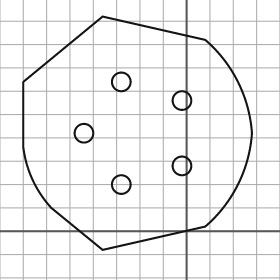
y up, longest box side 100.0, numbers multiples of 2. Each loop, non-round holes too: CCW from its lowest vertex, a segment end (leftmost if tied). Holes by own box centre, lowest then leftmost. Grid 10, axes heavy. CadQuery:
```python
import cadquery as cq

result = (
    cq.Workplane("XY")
    .moveTo(-36.0, -8.0)
    .lineTo(8.0, 2.0)
    .threePointArc((22.0, 20.0), (28.0, 42.0))
    .threePointArc((22.0, 64.0), (8.0, 82.0))
    .lineTo(-36.0, 92.0)
    .lineTo(-70.0, 64.0)
    .lineTo(-70.0, 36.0)
    .threePointArc((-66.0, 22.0), (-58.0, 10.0))
    .close()
    .moveTo(-28.0, 20.0)
    .circle(4.0)
    .moveTo(-2.0, 28.0)
    .circle(4.0)
    .moveTo(-44.0, 42.0)
    .circle(4.0)
    .moveTo(-2.0, 56.0)
    .circle(4.0)
    .moveTo(-28.0, 64.0)
    .circle(4.0)
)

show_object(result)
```